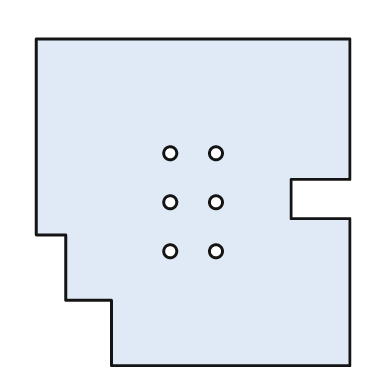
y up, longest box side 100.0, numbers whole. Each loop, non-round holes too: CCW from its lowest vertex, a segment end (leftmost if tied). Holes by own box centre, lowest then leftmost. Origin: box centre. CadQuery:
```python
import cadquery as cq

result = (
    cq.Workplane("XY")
    .moveTo(-25.0, -50.0)
    .lineTo(48.0, -50.0)
    .lineTo(48.0, -5.0)
    .lineTo(30.0, -5.0)
    .lineTo(30.0, 7.0)
    .lineTo(48.0, 7.0)
    .lineTo(48.0, 50.0)
    .lineTo(-48.0, 50.0)
    .lineTo(-48.0, -10.0)
    .lineTo(-39.0, -10.0)
    .lineTo(-39.0, -30.0)
    .lineTo(-25.0, -30.0)
    .close()
    .moveTo(-7.0, -15.0)
    .circle(2.0)
    .moveTo(7.0, -15.0)
    .circle(2.0)
    .moveTo(-7.0, 0.0)
    .circle(2.0)
    .moveTo(7.0, 0.0)
    .circle(2.0)
    .moveTo(-7.0, 15.0)
    .circle(2.0)
    .moveTo(7.0, 15.0)
    .circle(2.0)
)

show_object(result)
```